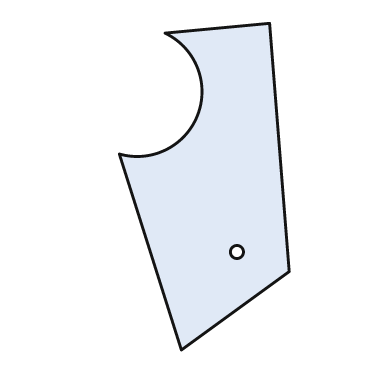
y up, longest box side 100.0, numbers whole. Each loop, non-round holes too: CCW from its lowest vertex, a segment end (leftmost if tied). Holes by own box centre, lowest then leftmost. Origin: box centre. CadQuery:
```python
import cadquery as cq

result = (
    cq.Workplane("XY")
    .moveTo(-7.0, -50.0)
    .lineTo(26.0, -26.0)
    .lineTo(20.0, 50.0)
    .lineTo(-12.0, 47.0)
    .threePointArc((-2.0, 22.0), (-26.0, 10.0))
    .close()
    .moveTo(10.0, -20.0)
    .circle(2.0)
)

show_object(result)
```